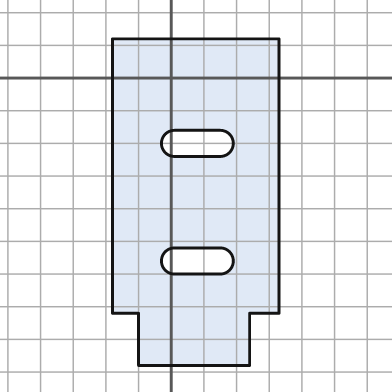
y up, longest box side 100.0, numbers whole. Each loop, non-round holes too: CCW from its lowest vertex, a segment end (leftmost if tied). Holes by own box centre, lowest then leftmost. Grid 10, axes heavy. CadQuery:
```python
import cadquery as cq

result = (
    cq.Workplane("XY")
    .moveTo(-10.0, -88.0)
    .lineTo(24.0, -88.0)
    .lineTo(24.0, -72.0)
    .lineTo(33.0, -72.0)
    .lineTo(33.0, 12.0)
    .lineTo(-18.0, 12.0)
    .lineTo(-18.0, -72.0)
    .lineTo(-10.0, -72.0)
    .close()
    .moveTo(1.0, -60.0)
    .lineTo(15.0, -60.0)
    .threePointArc((19.0, -56.0), (15.0, -52.0))
    .lineTo(1.0, -52.0)
    .threePointArc((-3.0, -56.0), (1.0, -60.0))
    .close()
    .moveTo(1.0, -24.0)
    .lineTo(15.0, -24.0)
    .threePointArc((19.0, -20.0), (15.0, -16.0))
    .lineTo(1.0, -16.0)
    .threePointArc((-3.0, -20.0), (1.0, -24.0))
    .close()
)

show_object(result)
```